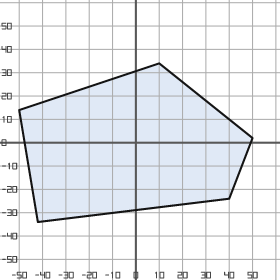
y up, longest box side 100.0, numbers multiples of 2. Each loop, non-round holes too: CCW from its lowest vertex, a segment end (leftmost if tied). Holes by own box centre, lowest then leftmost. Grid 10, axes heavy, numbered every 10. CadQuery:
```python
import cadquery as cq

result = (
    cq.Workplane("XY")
    .moveTo(-42.0, -34.0)
    .lineTo(40.0, -24.0)
    .lineTo(50.0, 2.0)
    .lineTo(10.0, 34.0)
    .lineTo(-50.0, 14.0)
    .close()
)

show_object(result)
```